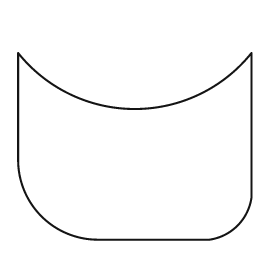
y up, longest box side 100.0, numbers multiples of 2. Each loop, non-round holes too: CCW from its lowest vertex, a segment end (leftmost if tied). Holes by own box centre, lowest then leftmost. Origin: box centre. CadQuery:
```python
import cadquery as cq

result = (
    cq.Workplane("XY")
    .moveTo(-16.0, -40.0)
    .lineTo(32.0, -40.0)
    .threePointArc((44.0, -34.0), (50.0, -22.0))
    .lineTo(50.0, 40.0)
    .threePointArc((0.0, 16.0), (-50.0, 40.0))
    .lineTo(-50.0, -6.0)
    .threePointArc((-40.0, -30.0), (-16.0, -40.0))
    .close()
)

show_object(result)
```